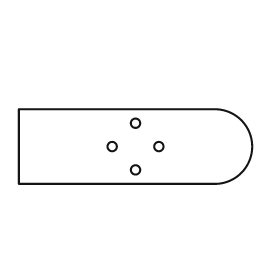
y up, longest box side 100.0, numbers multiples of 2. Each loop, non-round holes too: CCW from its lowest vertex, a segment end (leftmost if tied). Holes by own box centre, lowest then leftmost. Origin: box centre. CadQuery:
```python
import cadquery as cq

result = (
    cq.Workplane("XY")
    .moveTo(-50.0, -16.0)
    .lineTo(34.0, -16.0)
    .threePointArc((50.0, 0.0), (34.0, 16.0))
    .lineTo(-50.0, 16.0)
    .close()
    .moveTo(0.0, -10.0)
    .circle(2.0)
    .moveTo(-10.0, 0.0)
    .circle(2.0)
    .moveTo(10.0, 0.0)
    .circle(2.0)
    .moveTo(0.0, 10.0)
    .circle(2.0)
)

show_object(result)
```